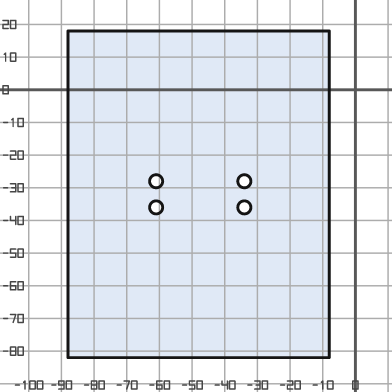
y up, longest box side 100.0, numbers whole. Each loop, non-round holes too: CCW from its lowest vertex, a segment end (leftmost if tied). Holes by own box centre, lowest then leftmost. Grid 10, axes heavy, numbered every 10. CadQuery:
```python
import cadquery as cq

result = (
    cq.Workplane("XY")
    .moveTo(-88.0, -82.0)
    .lineTo(-8.0, -82.0)
    .lineTo(-8.0, 18.0)
    .lineTo(-88.0, 18.0)
    .close()
    .moveTo(-61.0, -36.0)
    .circle(2.0)
    .moveTo(-34.0, -36.0)
    .circle(2.0)
    .moveTo(-61.0, -28.0)
    .circle(2.0)
    .moveTo(-34.0, -28.0)
    .circle(2.0)
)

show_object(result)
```